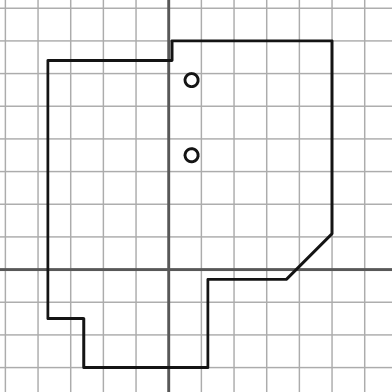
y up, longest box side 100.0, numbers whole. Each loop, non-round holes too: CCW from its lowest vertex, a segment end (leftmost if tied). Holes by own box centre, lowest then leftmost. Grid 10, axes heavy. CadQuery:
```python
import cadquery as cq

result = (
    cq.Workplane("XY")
    .moveTo(-26.0, -30.0)
    .lineTo(12.0, -30.0)
    .lineTo(12.0, -3.0)
    .lineTo(36.0, -3.0)
    .lineTo(50.0, 11.0)
    .lineTo(50.0, 70.0)
    .lineTo(1.0, 70.0)
    .lineTo(1.0, 64.0)
    .lineTo(-37.0, 64.0)
    .lineTo(-37.0, -15.0)
    .lineTo(-26.0, -15.0)
    .close()
    .moveTo(7.0, 35.0)
    .circle(2.0)
    .moveTo(7.0, 58.0)
    .circle(2.0)
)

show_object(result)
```